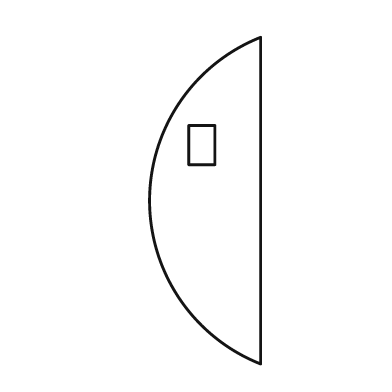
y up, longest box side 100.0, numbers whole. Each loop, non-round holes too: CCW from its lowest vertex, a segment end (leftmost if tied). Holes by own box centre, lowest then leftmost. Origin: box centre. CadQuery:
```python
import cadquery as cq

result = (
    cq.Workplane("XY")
    .moveTo(17.0, -50.0)
    .lineTo(17.0, 50.0)
    .threePointArc((-17.0, 0.0), (17.0, -50.0))
    .close()
    .moveTo(-5.0, 11.0)
    .lineTo(3.0, 11.0)
    .lineTo(3.0, 23.0)
    .lineTo(-5.0, 23.0)
    .close()
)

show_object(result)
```